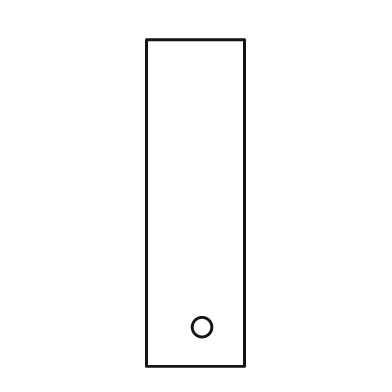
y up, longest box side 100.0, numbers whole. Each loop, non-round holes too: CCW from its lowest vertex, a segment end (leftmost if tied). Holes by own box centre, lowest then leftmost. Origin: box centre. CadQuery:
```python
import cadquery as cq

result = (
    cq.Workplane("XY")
    .moveTo(-15.0, -50.0)
    .lineTo(15.0, -50.0)
    .lineTo(15.0, 50.0)
    .lineTo(-15.0, 50.0)
    .close()
    .moveTo(2.0, -38.0)
    .circle(3.0)
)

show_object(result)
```